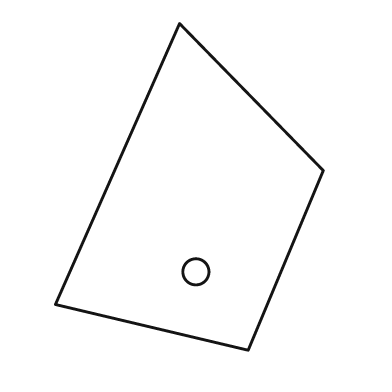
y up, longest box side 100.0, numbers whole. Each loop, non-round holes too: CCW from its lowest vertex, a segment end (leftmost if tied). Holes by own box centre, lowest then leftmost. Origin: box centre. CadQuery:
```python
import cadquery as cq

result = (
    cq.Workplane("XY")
    .moveTo(18.0, -50.0)
    .lineTo(41.0, 5.0)
    .lineTo(-3.0, 50.0)
    .lineTo(-41.0, -36.0)
    .close()
    .moveTo(2.0, -26.0)
    .circle(4.0)
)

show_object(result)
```